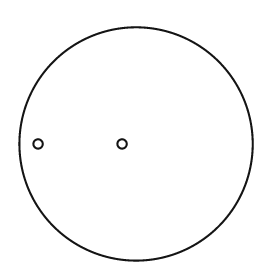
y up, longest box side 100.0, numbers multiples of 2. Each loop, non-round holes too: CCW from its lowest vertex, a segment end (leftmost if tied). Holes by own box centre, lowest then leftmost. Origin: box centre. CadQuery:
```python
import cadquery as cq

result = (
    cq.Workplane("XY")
    .moveTo(0.0, 0.0)
    .circle(50.0)
    .moveTo(-42.0, 0.0)
    .circle(2.0)
    .moveTo(-6.0, 0.0)
    .circle(2.0)
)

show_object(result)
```